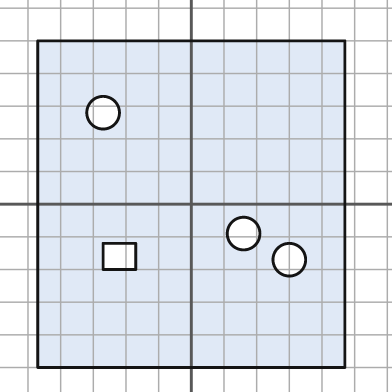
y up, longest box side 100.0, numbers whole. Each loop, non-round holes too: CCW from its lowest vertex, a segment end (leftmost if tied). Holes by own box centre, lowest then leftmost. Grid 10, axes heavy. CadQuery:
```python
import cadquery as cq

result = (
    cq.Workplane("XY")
    .moveTo(-47.0, -50.0)
    .lineTo(47.0, -50.0)
    .lineTo(47.0, 50.0)
    .lineTo(-47.0, 50.0)
    .close()
    .moveTo(30.0, -17.0)
    .circle(5.0)
    .moveTo(-27.0, -20.0)
    .lineTo(-17.0, -20.0)
    .lineTo(-17.0, -12.0)
    .lineTo(-27.0, -12.0)
    .close()
    .moveTo(16.0, -9.0)
    .circle(5.0)
    .moveTo(-27.0, 28.0)
    .circle(5.0)
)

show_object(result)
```